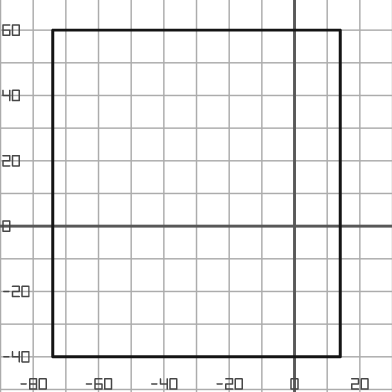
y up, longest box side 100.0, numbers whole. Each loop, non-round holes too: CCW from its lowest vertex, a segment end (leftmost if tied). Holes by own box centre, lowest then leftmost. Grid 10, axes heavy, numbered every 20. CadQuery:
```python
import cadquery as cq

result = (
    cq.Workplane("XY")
    .moveTo(-74.0, -40.0)
    .lineTo(14.0, -40.0)
    .lineTo(14.0, 60.0)
    .lineTo(-74.0, 60.0)
    .close()
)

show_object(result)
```